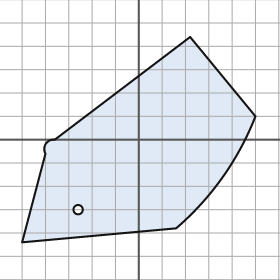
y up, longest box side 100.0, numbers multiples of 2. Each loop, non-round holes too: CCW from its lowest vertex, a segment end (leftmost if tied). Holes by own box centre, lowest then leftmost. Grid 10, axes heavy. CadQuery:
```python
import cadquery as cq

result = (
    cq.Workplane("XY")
    .moveTo(-50.0, -44.0)
    .lineTo(16.0, -38.0)
    .threePointArc((36.0, -16.0), (50.0, 10.0))
    .lineTo(22.0, 44.0)
    .lineTo(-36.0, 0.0)
    .threePointArc((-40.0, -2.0), (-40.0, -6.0))
    .close()
    .moveTo(-26.0, -30.0)
    .circle(2.0)
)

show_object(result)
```